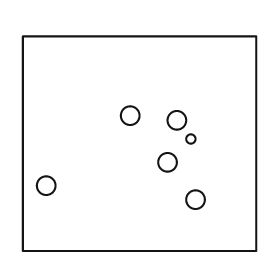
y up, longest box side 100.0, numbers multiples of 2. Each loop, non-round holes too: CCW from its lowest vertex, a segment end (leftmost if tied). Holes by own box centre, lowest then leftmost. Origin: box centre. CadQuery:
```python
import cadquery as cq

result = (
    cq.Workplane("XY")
    .moveTo(-50.0, -46.0)
    .lineTo(50.0, -46.0)
    .lineTo(50.0, 46.0)
    .lineTo(-50.0, 46.0)
    .close()
    .moveTo(24.0, -24.0)
    .circle(4.0)
    .moveTo(-40.0, -18.0)
    .circle(4.0)
    .moveTo(12.0, -8.0)
    .circle(4.0)
    .moveTo(22.0, 2.0)
    .circle(2.0)
    .moveTo(16.0, 10.0)
    .circle(4.0)
    .moveTo(-4.0, 12.0)
    .circle(4.0)
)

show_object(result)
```